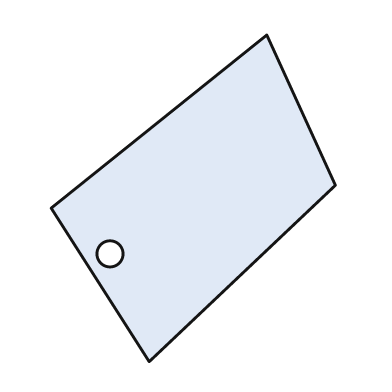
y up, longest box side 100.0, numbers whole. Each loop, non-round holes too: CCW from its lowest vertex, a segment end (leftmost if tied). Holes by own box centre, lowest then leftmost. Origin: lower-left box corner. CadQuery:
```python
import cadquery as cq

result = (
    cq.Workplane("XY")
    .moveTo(30.0, 0.0)
    .lineTo(87.0, 54.0)
    .lineTo(66.0, 100.0)
    .lineTo(0.0, 47.0)
    .close()
    .moveTo(18.0, 33.0)
    .circle(4.0)
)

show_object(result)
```